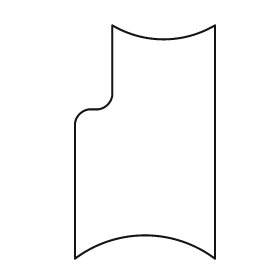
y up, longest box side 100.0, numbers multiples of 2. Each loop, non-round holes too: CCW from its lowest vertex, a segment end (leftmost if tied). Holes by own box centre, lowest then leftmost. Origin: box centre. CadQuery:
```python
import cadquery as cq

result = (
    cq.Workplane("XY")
    .moveTo(-30.0, -50.0)
    .threePointArc((0.0, -40.0), (30.0, -50.0))
    .lineTo(30.0, 50.0)
    .threePointArc((8.0, 44.0), (-14.0, 50.0))
    .lineTo(-14.0, 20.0)
    .threePointArc((-16.0, 16.0), (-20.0, 14.0))
    .lineTo(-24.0, 14.0)
    .threePointArc((-28.0, 12.0), (-30.0, 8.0))
    .close()
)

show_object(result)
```